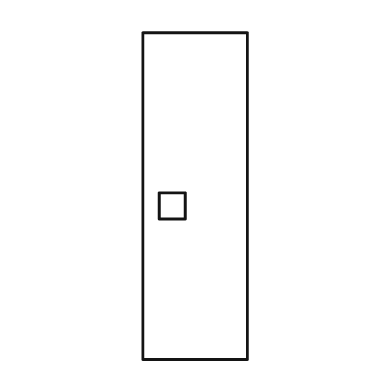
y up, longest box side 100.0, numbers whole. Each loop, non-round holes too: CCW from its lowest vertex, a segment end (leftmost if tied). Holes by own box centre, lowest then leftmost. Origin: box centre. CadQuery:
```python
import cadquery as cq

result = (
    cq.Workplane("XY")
    .moveTo(-16.0, -50.0)
    .lineTo(16.0, -50.0)
    .lineTo(16.0, 50.0)
    .lineTo(-16.0, 50.0)
    .close()
    .moveTo(-11.0, -7.0)
    .lineTo(-3.0, -7.0)
    .lineTo(-3.0, 1.0)
    .lineTo(-11.0, 1.0)
    .close()
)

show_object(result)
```